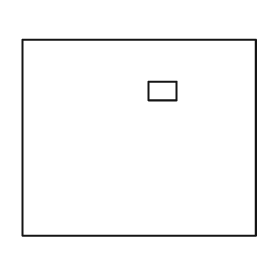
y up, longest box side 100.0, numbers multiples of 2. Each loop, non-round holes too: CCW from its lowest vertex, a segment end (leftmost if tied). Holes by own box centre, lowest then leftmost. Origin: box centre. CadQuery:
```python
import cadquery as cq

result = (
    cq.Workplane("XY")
    .moveTo(-50.0, -42.0)
    .lineTo(50.0, -42.0)
    .lineTo(50.0, 42.0)
    .lineTo(-50.0, 42.0)
    .close()
    .moveTo(4.0, 16.0)
    .lineTo(16.0, 16.0)
    .lineTo(16.0, 24.0)
    .lineTo(4.0, 24.0)
    .close()
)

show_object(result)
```